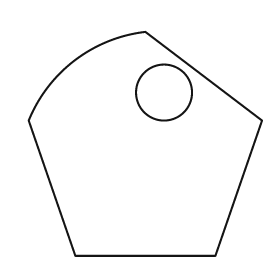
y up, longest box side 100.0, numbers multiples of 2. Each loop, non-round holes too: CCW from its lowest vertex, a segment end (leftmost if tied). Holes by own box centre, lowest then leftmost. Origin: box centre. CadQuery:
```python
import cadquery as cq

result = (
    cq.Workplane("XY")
    .moveTo(-30.0, -48.0)
    .lineTo(30.0, -48.0)
    .lineTo(50.0, 10.0)
    .lineTo(0.0, 48.0)
    .threePointArc((-30.0, 36.0), (-50.0, 10.0))
    .close()
    .moveTo(8.0, 22.0)
    .circle(12.0)
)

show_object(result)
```